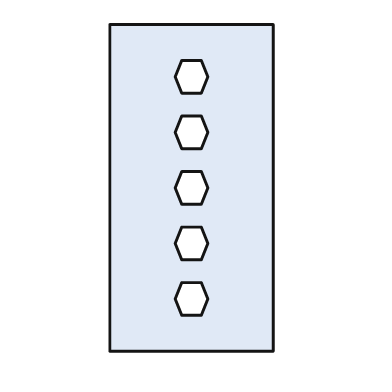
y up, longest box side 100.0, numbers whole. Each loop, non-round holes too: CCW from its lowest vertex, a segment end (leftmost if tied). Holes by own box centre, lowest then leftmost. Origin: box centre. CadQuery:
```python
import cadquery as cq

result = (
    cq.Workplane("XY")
    .moveTo(-25.0, -50.0)
    .lineTo(25.0, -50.0)
    .lineTo(25.0, 50.0)
    .lineTo(-25.0, 50.0)
    .close()
    .moveTo(-3.0, -39.0)
    .lineTo(3.0, -39.0)
    .lineTo(5.0, -34.0)
    .lineTo(3.0, -29.0)
    .lineTo(-3.0, -29.0)
    .lineTo(-5.0, -34.0)
    .close()
    .moveTo(-3.0, -22.0)
    .lineTo(3.0, -22.0)
    .lineTo(5.0, -17.0)
    .lineTo(3.0, -12.0)
    .lineTo(-3.0, -12.0)
    .lineTo(-5.0, -17.0)
    .close()
    .moveTo(-3.0, -5.0)
    .lineTo(3.0, -5.0)
    .lineTo(5.0, 0.0)
    .lineTo(3.0, 5.0)
    .lineTo(-3.0, 5.0)
    .lineTo(-5.0, 0.0)
    .close()
    .moveTo(-3.0, 12.0)
    .lineTo(3.0, 12.0)
    .lineTo(5.0, 17.0)
    .lineTo(3.0, 22.0)
    .lineTo(-3.0, 22.0)
    .lineTo(-5.0, 17.0)
    .close()
    .moveTo(-3.0, 29.0)
    .lineTo(3.0, 29.0)
    .lineTo(5.0, 34.0)
    .lineTo(3.0, 39.0)
    .lineTo(-3.0, 39.0)
    .lineTo(-5.0, 34.0)
    .close()
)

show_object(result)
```